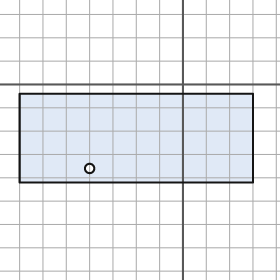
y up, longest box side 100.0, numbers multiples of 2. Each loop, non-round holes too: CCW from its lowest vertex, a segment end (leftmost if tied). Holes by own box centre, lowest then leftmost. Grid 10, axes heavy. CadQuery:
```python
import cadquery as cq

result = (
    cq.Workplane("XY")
    .moveTo(-70.0, -42.0)
    .lineTo(30.0, -42.0)
    .lineTo(30.0, -4.0)
    .lineTo(-70.0, -4.0)
    .close()
    .moveTo(-40.0, -36.0)
    .circle(2.0)
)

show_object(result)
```